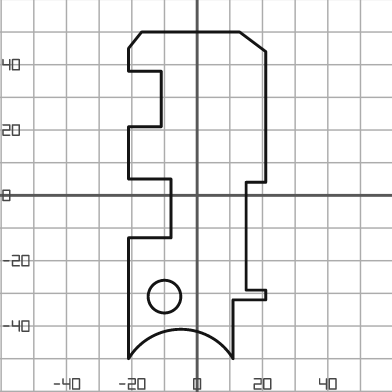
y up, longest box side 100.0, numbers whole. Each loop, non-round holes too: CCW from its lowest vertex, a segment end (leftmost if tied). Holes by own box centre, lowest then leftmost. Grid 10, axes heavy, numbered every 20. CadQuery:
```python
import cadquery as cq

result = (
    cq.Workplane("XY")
    .moveTo(-21.0, -50.0)
    .threePointArc((-5.0, -41.0), (11.0, -50.0))
    .lineTo(11.0, -32.0)
    .lineTo(21.0, -32.0)
    .lineTo(21.0, -29.0)
    .lineTo(15.0, -29.0)
    .lineTo(15.0, 4.0)
    .lineTo(21.0, 4.0)
    .lineTo(21.0, 44.0)
    .lineTo(13.0, 50.0)
    .lineTo(-17.0, 50.0)
    .lineTo(-21.0, 45.0)
    .lineTo(-21.0, 38.0)
    .lineTo(-11.0, 38.0)
    .lineTo(-11.0, 21.0)
    .lineTo(-21.0, 21.0)
    .lineTo(-21.0, 5.0)
    .lineTo(-8.0, 5.0)
    .lineTo(-8.0, -13.0)
    .lineTo(-21.0, -13.0)
    .close()
    .moveTo(-10.0, -31.0)
    .circle(5.0)
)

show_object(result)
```